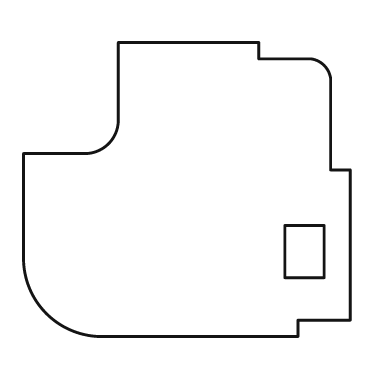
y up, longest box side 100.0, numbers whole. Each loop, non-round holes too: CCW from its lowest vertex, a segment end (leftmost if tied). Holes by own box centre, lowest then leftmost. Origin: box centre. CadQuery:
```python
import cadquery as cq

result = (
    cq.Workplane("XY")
    .moveTo(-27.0, -45.0)
    .lineTo(34.0, -45.0)
    .lineTo(34.0, -40.0)
    .lineTo(50.0, -40.0)
    .lineTo(50.0, 6.0)
    .lineTo(44.0, 6.0)
    .lineTo(44.0, 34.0)
    .threePointArc((42.0, 38.0), (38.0, 40.0))
    .lineTo(22.0, 40.0)
    .lineTo(22.0, 45.0)
    .lineTo(-21.0, 45.0)
    .lineTo(-21.0, 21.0)
    .threePointArc((-24.0, 14.0), (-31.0, 11.0))
    .lineTo(-50.0, 11.0)
    .lineTo(-50.0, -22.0)
    .threePointArc((-43.0, -38.0), (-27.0, -45.0))
    .close()
    .moveTo(30.0, -27.0)
    .lineTo(42.0, -27.0)
    .lineTo(42.0, -11.0)
    .lineTo(30.0, -11.0)
    .close()
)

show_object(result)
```